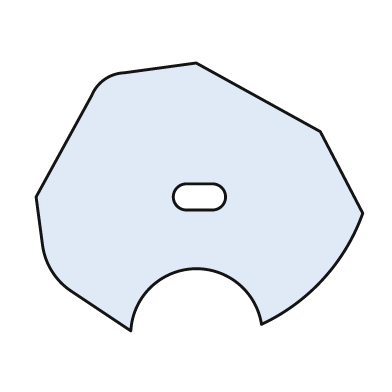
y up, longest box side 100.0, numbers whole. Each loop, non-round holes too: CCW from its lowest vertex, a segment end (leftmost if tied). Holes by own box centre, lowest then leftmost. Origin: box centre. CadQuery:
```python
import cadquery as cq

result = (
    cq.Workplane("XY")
    .moveTo(-21.0, -41.0)
    .threePointArc((-2.0, -22.0), (19.0, -39.0))
    .threePointArc((38.0, -25.0), (50.0, -5.0))
    .lineTo(37.0, 20.0)
    .lineTo(-1.0, 41.0)
    .lineTo(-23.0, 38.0)
    .threePointArc((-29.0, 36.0), (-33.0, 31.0))
    .lineTo(-50.0, 0.0)
    .lineTo(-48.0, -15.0)
    .threePointArc((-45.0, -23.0), (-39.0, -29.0))
    .close()
    .moveTo(-4.0, -4.0)
    .lineTo(4.0, -4.0)
    .threePointArc((8.0, 0.0), (4.0, 4.0))
    .lineTo(-4.0, 4.0)
    .threePointArc((-8.0, 0.0), (-4.0, -4.0))
    .close()
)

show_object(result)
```